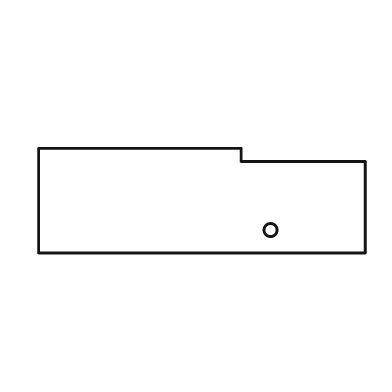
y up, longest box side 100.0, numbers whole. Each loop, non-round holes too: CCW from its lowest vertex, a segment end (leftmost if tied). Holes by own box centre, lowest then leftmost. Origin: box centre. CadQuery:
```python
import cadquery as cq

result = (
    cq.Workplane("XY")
    .moveTo(-50.0, -16.0)
    .lineTo(50.0, -16.0)
    .lineTo(50.0, 12.0)
    .lineTo(12.0, 12.0)
    .lineTo(12.0, 16.0)
    .lineTo(-50.0, 16.0)
    .close()
    .moveTo(21.0, -9.0)
    .circle(2.0)
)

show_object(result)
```